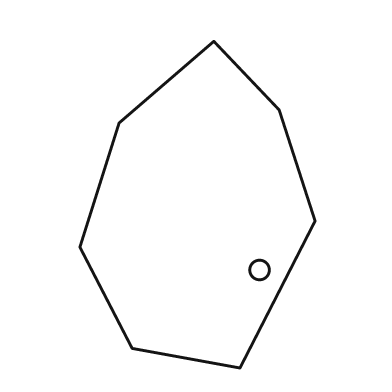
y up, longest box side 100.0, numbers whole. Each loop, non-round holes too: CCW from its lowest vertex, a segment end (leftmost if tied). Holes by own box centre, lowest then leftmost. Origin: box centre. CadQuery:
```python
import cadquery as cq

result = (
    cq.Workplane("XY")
    .moveTo(13.0, -50.0)
    .lineTo(36.0, -5.0)
    .lineTo(25.0, 29.0)
    .lineTo(5.0, 50.0)
    .lineTo(-24.0, 25.0)
    .lineTo(-36.0, -13.0)
    .lineTo(-20.0, -44.0)
    .close()
    .moveTo(19.0, -20.0)
    .circle(3.0)
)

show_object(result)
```